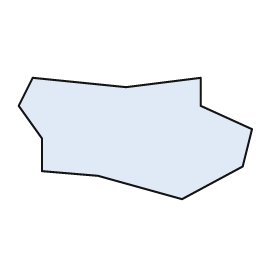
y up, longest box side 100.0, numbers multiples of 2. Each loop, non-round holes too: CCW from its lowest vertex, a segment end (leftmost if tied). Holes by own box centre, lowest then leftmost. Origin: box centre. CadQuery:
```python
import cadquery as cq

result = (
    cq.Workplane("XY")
    .moveTo(20.0, -26.0)
    .lineTo(46.0, -12.0)
    .lineTo(50.0, 4.0)
    .lineTo(28.0, 14.0)
    .lineTo(28.0, 26.0)
    .lineTo(-4.0, 22.0)
    .lineTo(-44.0, 26.0)
    .lineTo(-50.0, 14.0)
    .lineTo(-40.0, 0.0)
    .lineTo(-40.0, -14.0)
    .lineTo(-16.0, -16.0)
    .close()
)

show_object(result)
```